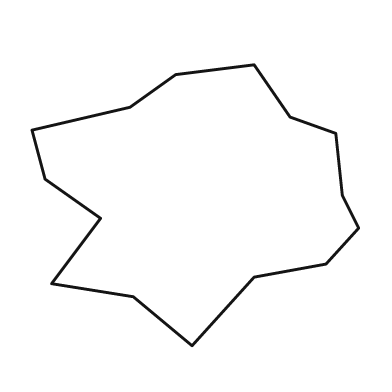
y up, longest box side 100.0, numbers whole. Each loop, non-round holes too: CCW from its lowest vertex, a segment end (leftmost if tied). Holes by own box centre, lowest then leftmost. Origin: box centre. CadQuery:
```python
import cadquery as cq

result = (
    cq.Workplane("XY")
    .moveTo(-1.0, -43.0)
    .lineTo(18.0, -22.0)
    .lineTo(40.0, -18.0)
    .lineTo(50.0, -7.0)
    .lineTo(45.0, 3.0)
    .lineTo(43.0, 22.0)
    .lineTo(29.0, 27.0)
    .lineTo(18.0, 43.0)
    .lineTo(-6.0, 40.0)
    .lineTo(-20.0, 30.0)
    .lineTo(-50.0, 23.0)
    .lineTo(-46.0, 8.0)
    .lineTo(-29.0, -4.0)
    .lineTo(-44.0, -24.0)
    .lineTo(-19.0, -28.0)
    .close()
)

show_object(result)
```